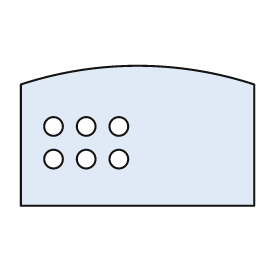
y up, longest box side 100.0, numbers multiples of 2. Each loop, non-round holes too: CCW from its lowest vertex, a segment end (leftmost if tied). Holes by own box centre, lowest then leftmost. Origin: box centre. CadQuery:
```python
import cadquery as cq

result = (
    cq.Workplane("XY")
    .moveTo(-50.0, -30.0)
    .lineTo(50.0, -30.0)
    .lineTo(50.0, 22.0)
    .threePointArc((0.0, 30.0), (-50.0, 22.0))
    .close()
    .moveTo(-36.0, -10.0)
    .circle(4.0)
    .moveTo(-22.0, -10.0)
    .circle(4.0)
    .moveTo(-8.0, -10.0)
    .circle(4.0)
    .moveTo(-36.0, 4.0)
    .circle(4.0)
    .moveTo(-22.0, 4.0)
    .circle(4.0)
    .moveTo(-8.0, 4.0)
    .circle(4.0)
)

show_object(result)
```